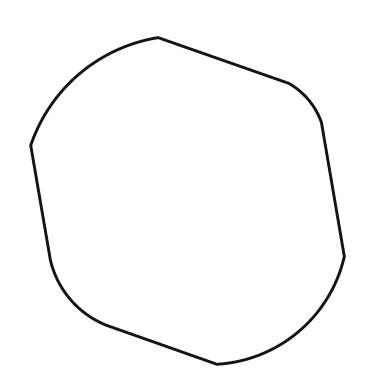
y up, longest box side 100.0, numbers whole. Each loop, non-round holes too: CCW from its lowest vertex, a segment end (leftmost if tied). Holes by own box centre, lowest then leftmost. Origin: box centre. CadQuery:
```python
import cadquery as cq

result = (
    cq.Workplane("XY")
    .moveTo(9.0, -50.0)
    .threePointArc((34.0, -40.0), (48.0, -17.0))
    .lineTo(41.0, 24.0)
    .threePointArc((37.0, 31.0), (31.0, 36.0))
    .lineTo(-9.0, 50.0)
    .threePointArc((-33.0, 39.0), (-48.0, 17.0))
    .lineTo(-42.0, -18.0)
    .threePointArc((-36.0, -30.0), (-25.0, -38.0))
    .close()
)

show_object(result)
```